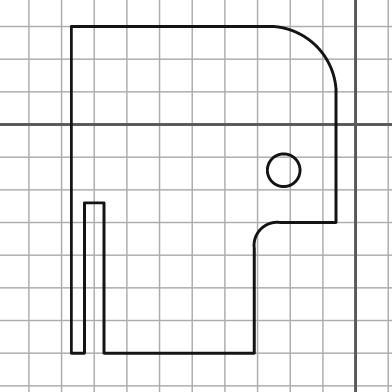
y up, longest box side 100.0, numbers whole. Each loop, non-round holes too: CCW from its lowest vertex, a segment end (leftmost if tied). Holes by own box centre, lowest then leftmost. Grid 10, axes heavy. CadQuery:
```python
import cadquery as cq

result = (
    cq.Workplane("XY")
    .moveTo(-87.0, -70.0)
    .lineTo(-83.0, -70.0)
    .lineTo(-83.0, -24.0)
    .lineTo(-77.0, -24.0)
    .lineTo(-77.0, -70.0)
    .lineTo(-31.0, -70.0)
    .lineTo(-31.0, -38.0)
    .threePointArc((-29.0, -32.0), (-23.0, -30.0))
    .lineTo(-6.0, -30.0)
    .lineTo(-6.0, 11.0)
    .threePointArc((-12.0, 24.0), (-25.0, 30.0))
    .lineTo(-87.0, 30.0)
    .close()
    .moveTo(-22.0, -14.0)
    .circle(5.0)
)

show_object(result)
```